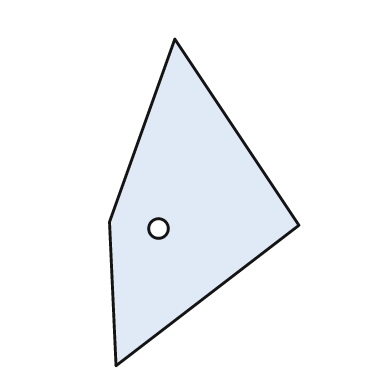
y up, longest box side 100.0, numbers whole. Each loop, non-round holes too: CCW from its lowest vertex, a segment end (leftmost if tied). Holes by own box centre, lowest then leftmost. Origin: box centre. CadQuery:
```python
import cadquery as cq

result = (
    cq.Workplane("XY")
    .moveTo(-27.0, -50.0)
    .lineTo(29.0, -7.0)
    .lineTo(-9.0, 50.0)
    .lineTo(-29.0, -6.0)
    .close()
    .moveTo(-14.0, -8.0)
    .circle(3.0)
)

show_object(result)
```